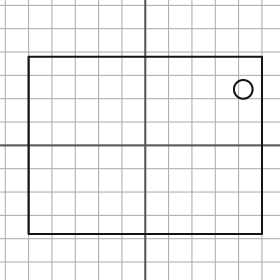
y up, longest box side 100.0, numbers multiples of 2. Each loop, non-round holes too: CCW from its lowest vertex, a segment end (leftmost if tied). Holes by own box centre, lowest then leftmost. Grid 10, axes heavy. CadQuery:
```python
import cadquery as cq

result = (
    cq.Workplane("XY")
    .moveTo(-50.0, -38.0)
    .lineTo(50.0, -38.0)
    .lineTo(50.0, 38.0)
    .lineTo(-50.0, 38.0)
    .close()
    .moveTo(42.0, 24.0)
    .circle(4.0)
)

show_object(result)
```